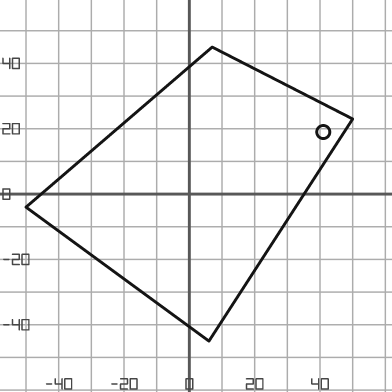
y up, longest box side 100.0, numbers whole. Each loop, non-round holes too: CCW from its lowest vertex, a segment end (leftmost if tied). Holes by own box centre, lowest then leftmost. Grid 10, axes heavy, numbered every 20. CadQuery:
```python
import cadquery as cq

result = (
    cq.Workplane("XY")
    .moveTo(6.0, -45.0)
    .lineTo(50.0, 23.0)
    .lineTo(7.0, 45.0)
    .lineTo(-50.0, -4.0)
    .close()
    .moveTo(41.0, 19.0)
    .circle(2.0)
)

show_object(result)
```